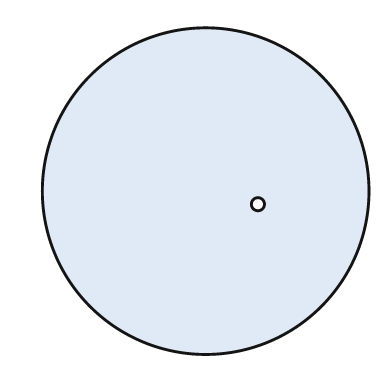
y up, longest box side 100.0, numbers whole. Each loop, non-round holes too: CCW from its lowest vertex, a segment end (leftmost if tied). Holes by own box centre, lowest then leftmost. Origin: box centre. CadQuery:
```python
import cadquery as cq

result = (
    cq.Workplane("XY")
    .moveTo(0.0, 0.0)
    .circle(50.0)
    .moveTo(16.0, -4.0)
    .circle(2.0)
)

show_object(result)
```